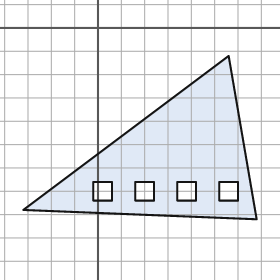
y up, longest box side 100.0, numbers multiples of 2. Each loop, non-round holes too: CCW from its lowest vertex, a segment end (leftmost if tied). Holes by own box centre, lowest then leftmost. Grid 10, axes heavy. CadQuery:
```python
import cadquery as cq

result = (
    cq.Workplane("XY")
    .moveTo(68.0, -82.0)
    .lineTo(56.0, -12.0)
    .lineTo(-32.0, -78.0)
    .close()
    .moveTo(-2.0, -74.0)
    .lineTo(6.0, -74.0)
    .lineTo(6.0, -66.0)
    .lineTo(-2.0, -66.0)
    .close()
    .moveTo(16.0, -74.0)
    .lineTo(24.0, -74.0)
    .lineTo(24.0, -66.0)
    .lineTo(16.0, -66.0)
    .close()
    .moveTo(34.0, -74.0)
    .lineTo(42.0, -74.0)
    .lineTo(42.0, -66.0)
    .lineTo(34.0, -66.0)
    .close()
    .moveTo(52.0, -74.0)
    .lineTo(60.0, -74.0)
    .lineTo(60.0, -66.0)
    .lineTo(52.0, -66.0)
    .close()
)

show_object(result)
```